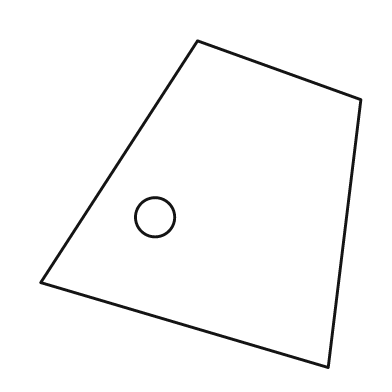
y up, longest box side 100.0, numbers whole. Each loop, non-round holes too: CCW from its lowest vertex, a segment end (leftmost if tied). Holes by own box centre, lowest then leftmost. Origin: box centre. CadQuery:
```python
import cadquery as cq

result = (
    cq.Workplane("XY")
    .moveTo(39.0, -50.0)
    .lineTo(49.0, 32.0)
    .lineTo(-1.0, 50.0)
    .lineTo(-49.0, -24.0)
    .close()
    .moveTo(-14.0, -4.0)
    .circle(6.0)
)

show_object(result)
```